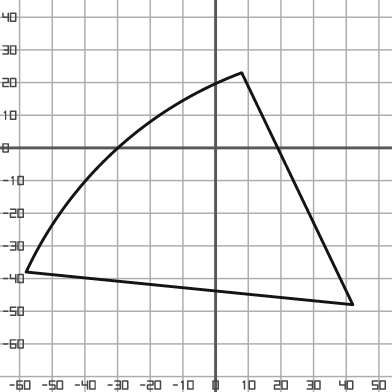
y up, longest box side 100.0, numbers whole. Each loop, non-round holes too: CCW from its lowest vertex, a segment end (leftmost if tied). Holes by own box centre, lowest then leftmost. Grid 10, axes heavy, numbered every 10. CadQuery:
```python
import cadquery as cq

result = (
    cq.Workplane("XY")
    .moveTo(42.0, -48.0)
    .lineTo(8.0, 23.0)
    .threePointArc((-31.0, -1.0), (-58.0, -38.0))
    .close()
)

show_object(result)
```